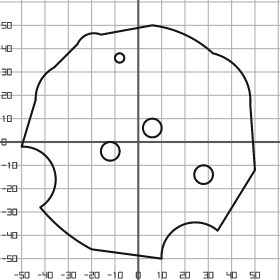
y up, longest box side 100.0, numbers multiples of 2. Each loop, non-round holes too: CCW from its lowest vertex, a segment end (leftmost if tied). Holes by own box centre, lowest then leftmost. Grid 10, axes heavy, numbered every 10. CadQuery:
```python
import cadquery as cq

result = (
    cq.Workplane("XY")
    .moveTo(10.0, -50.0)
    .threePointArc((18.0, -36.0), (34.0, -38.0))
    .lineTo(50.0, -12.0)
    .lineTo(48.0, 16.0)
    .threePointArc((44.0, 30.0), (32.0, 38.0))
    .threePointArc((20.0, 46.0), (6.0, 50.0))
    .lineTo(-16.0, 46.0)
    .threePointArc((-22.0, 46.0), (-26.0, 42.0))
    .lineTo(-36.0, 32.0)
    .threePointArc((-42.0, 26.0), (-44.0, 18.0))
    .lineTo(-50.0, -2.0)
    .threePointArc((-36.0, -12.0), (-42.0, -28.0))
    .threePointArc((-32.0, -38.0), (-20.0, -46.0))
    .close()
    .moveTo(28.0, -14.0)
    .circle(4.0)
    .moveTo(-12.0, -4.0)
    .circle(4.0)
    .moveTo(6.0, 6.0)
    .circle(4.0)
    .moveTo(-8.0, 36.0)
    .circle(2.0)
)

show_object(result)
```